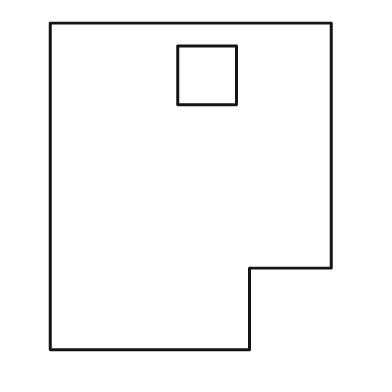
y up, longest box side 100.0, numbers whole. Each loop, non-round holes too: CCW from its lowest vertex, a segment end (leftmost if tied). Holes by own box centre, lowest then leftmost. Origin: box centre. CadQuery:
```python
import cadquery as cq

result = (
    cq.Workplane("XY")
    .moveTo(-43.0, -50.0)
    .lineTo(18.0, -50.0)
    .lineTo(18.0, -25.0)
    .lineTo(43.0, -25.0)
    .lineTo(43.0, 50.0)
    .lineTo(-43.0, 50.0)
    .close()
    .moveTo(-4.0, 25.0)
    .lineTo(14.0, 25.0)
    .lineTo(14.0, 43.0)
    .lineTo(-4.0, 43.0)
    .close()
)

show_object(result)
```